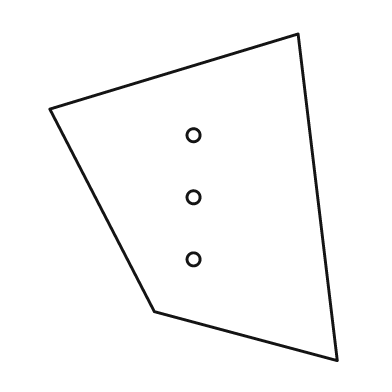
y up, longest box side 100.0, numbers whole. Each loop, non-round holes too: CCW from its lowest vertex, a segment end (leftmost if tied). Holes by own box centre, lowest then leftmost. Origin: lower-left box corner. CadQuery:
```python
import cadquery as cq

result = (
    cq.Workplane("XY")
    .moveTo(88.0, 0.0)
    .lineTo(76.0, 100.0)
    .lineTo(0.0, 77.0)
    .lineTo(32.0, 15.0)
    .close()
    .moveTo(44.0, 31.0)
    .circle(2.0)
    .moveTo(44.0, 50.0)
    .circle(2.0)
    .moveTo(44.0, 69.0)
    .circle(2.0)
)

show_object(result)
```